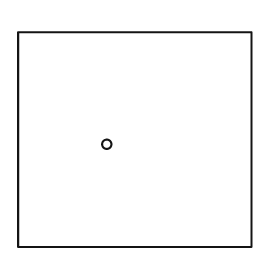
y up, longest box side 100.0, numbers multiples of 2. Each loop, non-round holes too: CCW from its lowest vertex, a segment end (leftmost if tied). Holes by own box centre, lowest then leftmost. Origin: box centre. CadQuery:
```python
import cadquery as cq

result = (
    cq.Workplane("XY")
    .moveTo(-50.0, -46.0)
    .lineTo(50.0, -46.0)
    .lineTo(50.0, 46.0)
    .lineTo(-50.0, 46.0)
    .close()
    .moveTo(-12.0, -2.0)
    .circle(2.0)
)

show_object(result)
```